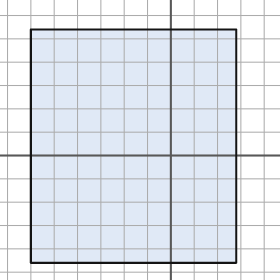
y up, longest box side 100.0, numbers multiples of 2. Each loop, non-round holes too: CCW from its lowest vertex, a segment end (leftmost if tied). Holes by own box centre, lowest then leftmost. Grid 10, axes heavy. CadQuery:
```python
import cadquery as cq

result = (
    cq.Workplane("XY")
    .moveTo(-60.0, -46.0)
    .lineTo(28.0, -46.0)
    .lineTo(28.0, 54.0)
    .lineTo(-60.0, 54.0)
    .close()
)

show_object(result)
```